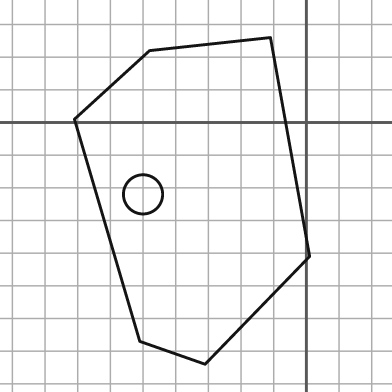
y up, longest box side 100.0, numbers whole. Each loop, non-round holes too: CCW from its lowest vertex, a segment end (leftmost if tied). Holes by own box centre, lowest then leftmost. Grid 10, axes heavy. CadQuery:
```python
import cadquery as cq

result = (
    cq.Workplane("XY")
    .moveTo(-31.0, -74.0)
    .lineTo(1.0, -41.0)
    .lineTo(-11.0, 26.0)
    .lineTo(-48.0, 22.0)
    .lineTo(-71.0, 1.0)
    .lineTo(-51.0, -67.0)
    .close()
    .moveTo(-50.0, -22.0)
    .circle(6.0)
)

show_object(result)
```